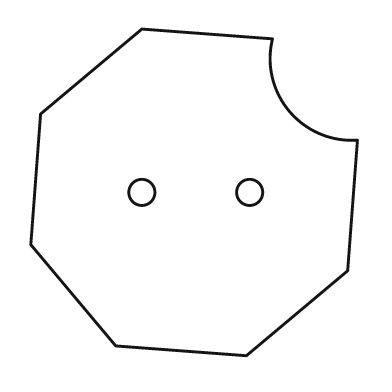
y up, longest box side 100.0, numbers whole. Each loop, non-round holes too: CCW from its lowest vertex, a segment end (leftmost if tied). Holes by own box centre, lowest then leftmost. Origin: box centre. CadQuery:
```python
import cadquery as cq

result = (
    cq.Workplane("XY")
    .moveTo(16.0, -50.0)
    .lineTo(47.0, -24.0)
    .lineTo(50.0, 16.0)
    .threePointArc((29.0, 25.0), (24.0, 47.0))
    .lineTo(-16.0, 50.0)
    .lineTo(-47.0, 24.0)
    .lineTo(-50.0, -16.0)
    .lineTo(-24.0, -47.0)
    .close()
    .moveTo(-16.0, 0.0)
    .circle(4.0)
    .moveTo(17.0, 0.0)
    .circle(4.0)
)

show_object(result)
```